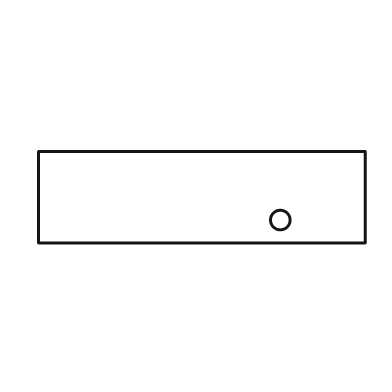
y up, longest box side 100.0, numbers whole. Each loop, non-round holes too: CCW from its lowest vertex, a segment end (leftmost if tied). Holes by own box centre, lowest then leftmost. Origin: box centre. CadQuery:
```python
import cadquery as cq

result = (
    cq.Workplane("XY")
    .moveTo(-50.0, -14.0)
    .lineTo(50.0, -14.0)
    .lineTo(50.0, 14.0)
    .lineTo(-50.0, 14.0)
    .close()
    .moveTo(24.0, -7.0)
    .circle(3.0)
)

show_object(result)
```